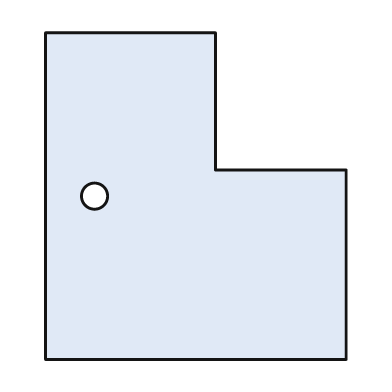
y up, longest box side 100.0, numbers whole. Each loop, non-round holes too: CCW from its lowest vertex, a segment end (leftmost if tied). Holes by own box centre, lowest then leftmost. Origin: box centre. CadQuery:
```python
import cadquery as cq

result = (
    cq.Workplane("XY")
    .moveTo(-46.0, -50.0)
    .lineTo(46.0, -50.0)
    .lineTo(46.0, 8.0)
    .lineTo(6.0, 8.0)
    .lineTo(6.0, 50.0)
    .lineTo(-46.0, 50.0)
    .close()
    .moveTo(-31.0, 0.0)
    .circle(4.0)
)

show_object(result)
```